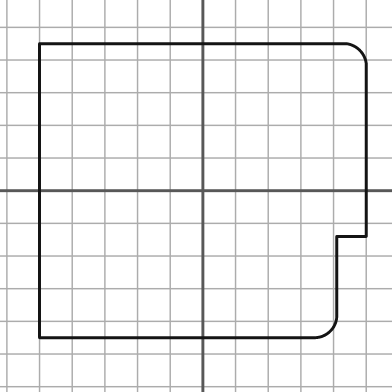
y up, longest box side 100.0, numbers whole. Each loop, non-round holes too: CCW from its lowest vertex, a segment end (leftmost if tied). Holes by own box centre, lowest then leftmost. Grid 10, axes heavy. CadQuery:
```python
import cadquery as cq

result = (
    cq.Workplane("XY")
    .moveTo(-50.0, -45.0)
    .lineTo(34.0, -45.0)
    .threePointArc((39.0, -43.0), (41.0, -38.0))
    .lineTo(41.0, -14.0)
    .lineTo(50.0, -14.0)
    .lineTo(50.0, 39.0)
    .threePointArc((48.0, 43.0), (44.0, 45.0))
    .lineTo(-50.0, 45.0)
    .close()
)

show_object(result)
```